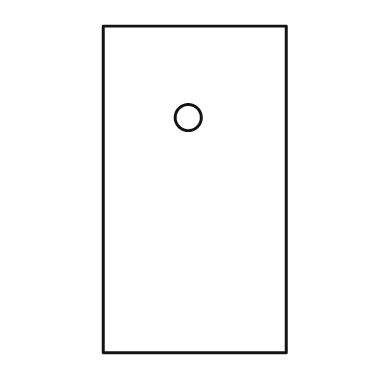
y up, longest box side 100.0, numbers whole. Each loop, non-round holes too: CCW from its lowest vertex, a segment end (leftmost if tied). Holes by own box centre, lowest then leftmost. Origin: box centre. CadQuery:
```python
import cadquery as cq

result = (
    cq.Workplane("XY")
    .moveTo(-28.0, -50.0)
    .lineTo(28.0, -50.0)
    .lineTo(28.0, 50.0)
    .lineTo(-28.0, 50.0)
    .close()
    .moveTo(-2.0, 22.0)
    .circle(4.0)
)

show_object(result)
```